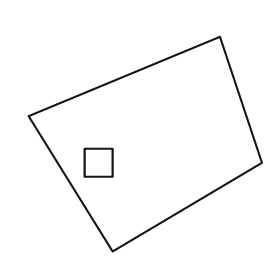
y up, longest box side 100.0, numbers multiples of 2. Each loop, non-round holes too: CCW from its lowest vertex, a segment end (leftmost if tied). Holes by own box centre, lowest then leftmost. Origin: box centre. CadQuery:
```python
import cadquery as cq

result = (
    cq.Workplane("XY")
    .moveTo(-14.0, -46.0)
    .lineTo(50.0, -8.0)
    .lineTo(32.0, 46.0)
    .lineTo(-50.0, 12.0)
    .close()
    .moveTo(-26.0, -14.0)
    .lineTo(-14.0, -14.0)
    .lineTo(-14.0, -2.0)
    .lineTo(-26.0, -2.0)
    .close()
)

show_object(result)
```